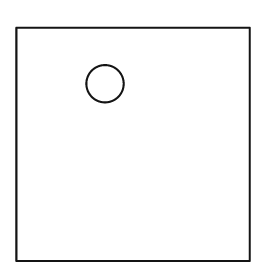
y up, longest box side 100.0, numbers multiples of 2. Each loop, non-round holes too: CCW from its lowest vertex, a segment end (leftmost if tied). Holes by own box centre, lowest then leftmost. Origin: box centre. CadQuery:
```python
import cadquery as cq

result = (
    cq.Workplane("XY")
    .moveTo(-50.0, -50.0)
    .lineTo(50.0, -50.0)
    .lineTo(50.0, 50.0)
    .lineTo(-50.0, 50.0)
    .close()
    .moveTo(-12.0, 26.0)
    .circle(8.0)
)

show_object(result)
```